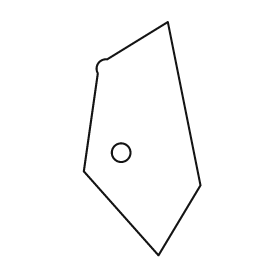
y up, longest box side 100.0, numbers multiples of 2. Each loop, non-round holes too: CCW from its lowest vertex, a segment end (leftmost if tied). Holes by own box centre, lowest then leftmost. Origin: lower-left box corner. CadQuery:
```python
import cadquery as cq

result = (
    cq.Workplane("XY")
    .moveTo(32.0, 0.0)
    .lineTo(50.0, 30.0)
    .lineTo(36.0, 100.0)
    .lineTo(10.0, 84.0)
    .threePointArc((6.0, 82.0), (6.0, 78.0))
    .lineTo(0.0, 36.0)
    .close()
    .moveTo(16.0, 44.0)
    .circle(4.0)
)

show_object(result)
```